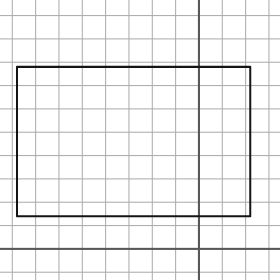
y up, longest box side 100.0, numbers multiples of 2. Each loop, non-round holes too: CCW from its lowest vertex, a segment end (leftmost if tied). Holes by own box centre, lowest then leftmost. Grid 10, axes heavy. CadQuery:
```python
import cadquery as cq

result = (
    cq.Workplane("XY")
    .moveTo(-78.0, 14.0)
    .lineTo(22.0, 14.0)
    .lineTo(22.0, 78.0)
    .lineTo(-78.0, 78.0)
    .close()
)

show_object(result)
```